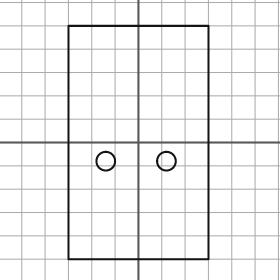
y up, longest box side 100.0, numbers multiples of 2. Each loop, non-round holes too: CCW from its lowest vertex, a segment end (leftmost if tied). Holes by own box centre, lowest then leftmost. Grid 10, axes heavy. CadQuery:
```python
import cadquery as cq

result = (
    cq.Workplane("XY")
    .moveTo(-30.0, -50.0)
    .lineTo(30.0, -50.0)
    .lineTo(30.0, 50.0)
    .lineTo(-30.0, 50.0)
    .close()
    .moveTo(-14.0, -8.0)
    .circle(4.0)
    .moveTo(12.0, -8.0)
    .circle(4.0)
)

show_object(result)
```